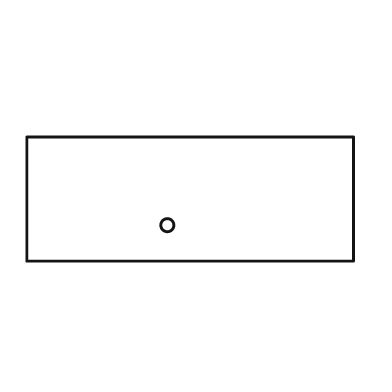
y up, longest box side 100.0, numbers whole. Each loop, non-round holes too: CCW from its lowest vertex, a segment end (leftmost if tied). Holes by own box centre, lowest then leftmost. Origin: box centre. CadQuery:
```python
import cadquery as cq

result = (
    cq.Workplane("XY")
    .moveTo(-50.0, -19.0)
    .lineTo(50.0, -19.0)
    .lineTo(50.0, 19.0)
    .lineTo(-50.0, 19.0)
    .close()
    .moveTo(-7.0, -8.0)
    .circle(2.0)
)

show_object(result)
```